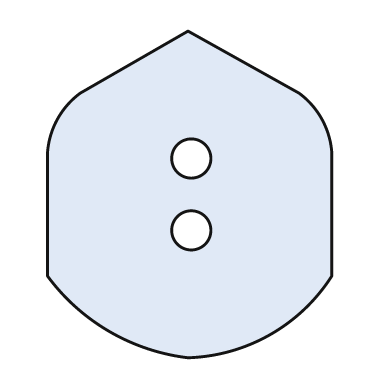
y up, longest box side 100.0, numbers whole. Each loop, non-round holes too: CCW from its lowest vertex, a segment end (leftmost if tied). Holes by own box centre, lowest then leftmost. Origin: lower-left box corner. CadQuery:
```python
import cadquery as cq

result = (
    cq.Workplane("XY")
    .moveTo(43.0, 0.0)
    .threePointArc((68.0, 7.0), (87.0, 25.0))
    .lineTo(87.0, 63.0)
    .threePointArc((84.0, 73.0), (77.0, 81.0))
    .lineTo(43.0, 100.0)
    .lineTo(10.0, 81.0)
    .threePointArc((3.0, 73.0), (0.0, 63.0))
    .lineTo(0.0, 25.0)
    .threePointArc((19.0, 8.0), (43.0, 0.0))
    .close()
    .moveTo(44.0, 39.0)
    .circle(6.0)
    .moveTo(44.0, 61.0)
    .circle(6.0)
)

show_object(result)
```